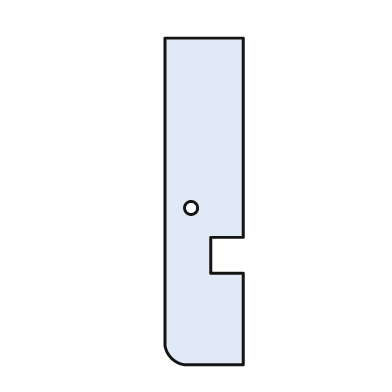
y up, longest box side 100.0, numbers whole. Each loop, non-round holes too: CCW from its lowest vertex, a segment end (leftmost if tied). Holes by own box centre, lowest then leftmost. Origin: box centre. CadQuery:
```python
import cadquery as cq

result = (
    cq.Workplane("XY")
    .moveTo(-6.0, -50.0)
    .lineTo(12.0, -50.0)
    .lineTo(12.0, -22.0)
    .lineTo(2.0, -22.0)
    .lineTo(2.0, -11.0)
    .lineTo(12.0, -11.0)
    .lineTo(12.0, 50.0)
    .lineTo(-12.0, 50.0)
    .lineTo(-12.0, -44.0)
    .threePointArc((-10.0, -48.0), (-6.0, -50.0))
    .close()
    .moveTo(-4.0, -2.0)
    .circle(2.0)
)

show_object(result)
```